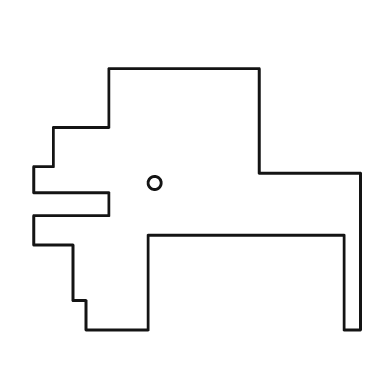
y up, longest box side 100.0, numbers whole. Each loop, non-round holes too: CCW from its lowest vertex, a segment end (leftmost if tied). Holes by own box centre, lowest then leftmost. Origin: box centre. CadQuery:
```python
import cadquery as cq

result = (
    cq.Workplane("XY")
    .moveTo(-34.0, -40.0)
    .lineTo(-15.0, -40.0)
    .lineTo(-15.0, -11.0)
    .lineTo(45.0, -11.0)
    .lineTo(45.0, -40.0)
    .lineTo(50.0, -40.0)
    .lineTo(50.0, 8.0)
    .lineTo(19.0, 8.0)
    .lineTo(19.0, 40.0)
    .lineTo(-27.0, 40.0)
    .lineTo(-27.0, 22.0)
    .lineTo(-44.0, 22.0)
    .lineTo(-44.0, 10.0)
    .lineTo(-50.0, 10.0)
    .lineTo(-50.0, 2.0)
    .lineTo(-27.0, 2.0)
    .lineTo(-27.0, -5.0)
    .lineTo(-50.0, -5.0)
    .lineTo(-50.0, -14.0)
    .lineTo(-38.0, -14.0)
    .lineTo(-38.0, -31.0)
    .lineTo(-34.0, -31.0)
    .close()
    .moveTo(-13.0, 5.0)
    .circle(2.0)
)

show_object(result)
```